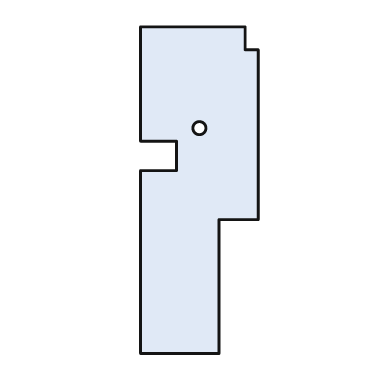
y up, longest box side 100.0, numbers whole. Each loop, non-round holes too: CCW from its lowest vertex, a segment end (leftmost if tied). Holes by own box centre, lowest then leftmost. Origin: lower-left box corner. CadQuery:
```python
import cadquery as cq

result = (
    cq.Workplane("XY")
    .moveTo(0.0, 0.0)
    .lineTo(24.0, 0.0)
    .lineTo(24.0, 41.0)
    .lineTo(36.0, 41.0)
    .lineTo(36.0, 93.0)
    .lineTo(32.0, 93.0)
    .lineTo(32.0, 100.0)
    .lineTo(0.0, 100.0)
    .lineTo(0.0, 65.0)
    .lineTo(11.0, 65.0)
    .lineTo(11.0, 56.0)
    .lineTo(0.0, 56.0)
    .close()
    .moveTo(18.0, 69.0)
    .circle(2.0)
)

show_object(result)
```